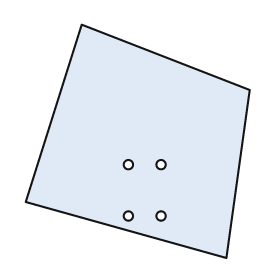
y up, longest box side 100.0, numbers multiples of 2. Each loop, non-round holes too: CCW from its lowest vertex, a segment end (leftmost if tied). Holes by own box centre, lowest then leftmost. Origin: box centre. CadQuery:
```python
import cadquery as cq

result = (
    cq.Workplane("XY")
    .moveTo(38.0, -50.0)
    .lineTo(48.0, 22.0)
    .lineTo(-24.0, 50.0)
    .lineTo(-48.0, -26.0)
    .close()
    .moveTo(-4.0, -32.0)
    .circle(2.0)
    .moveTo(10.0, -32.0)
    .circle(2.0)
    .moveTo(-4.0, -10.0)
    .circle(2.0)
    .moveTo(10.0, -10.0)
    .circle(2.0)
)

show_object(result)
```